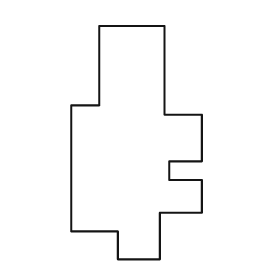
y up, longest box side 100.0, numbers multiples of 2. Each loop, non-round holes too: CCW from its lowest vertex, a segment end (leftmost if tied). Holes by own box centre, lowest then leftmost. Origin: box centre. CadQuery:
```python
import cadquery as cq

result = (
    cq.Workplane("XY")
    .moveTo(-8.0, -50.0)
    .lineTo(10.0, -50.0)
    .lineTo(10.0, -30.0)
    .lineTo(28.0, -30.0)
    .lineTo(28.0, -16.0)
    .lineTo(14.0, -16.0)
    .lineTo(14.0, -8.0)
    .lineTo(28.0, -8.0)
    .lineTo(28.0, 12.0)
    .lineTo(12.0, 12.0)
    .lineTo(12.0, 50.0)
    .lineTo(-16.0, 50.0)
    .lineTo(-16.0, 16.0)
    .lineTo(-28.0, 16.0)
    .lineTo(-28.0, -38.0)
    .lineTo(-8.0, -38.0)
    .close()
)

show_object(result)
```